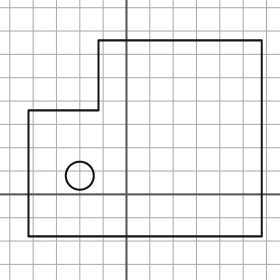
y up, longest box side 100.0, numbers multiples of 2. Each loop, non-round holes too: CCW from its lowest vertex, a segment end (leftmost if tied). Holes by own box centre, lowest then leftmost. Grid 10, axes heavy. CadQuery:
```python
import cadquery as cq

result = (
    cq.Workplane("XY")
    .moveTo(-42.0, -18.0)
    .lineTo(58.0, -18.0)
    .lineTo(58.0, 66.0)
    .lineTo(-12.0, 66.0)
    .lineTo(-12.0, 36.0)
    .lineTo(-42.0, 36.0)
    .close()
    .moveTo(-20.0, 8.0)
    .circle(6.0)
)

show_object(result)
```